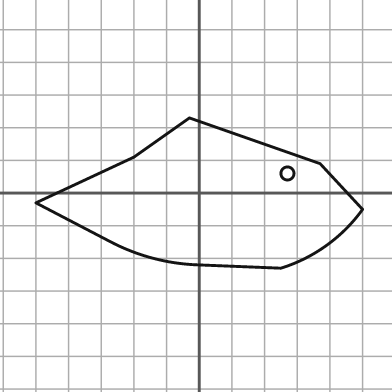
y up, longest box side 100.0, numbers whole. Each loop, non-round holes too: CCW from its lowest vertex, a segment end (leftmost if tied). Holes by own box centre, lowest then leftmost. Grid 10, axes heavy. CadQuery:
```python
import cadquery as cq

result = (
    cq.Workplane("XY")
    .moveTo(25.0, -23.0)
    .threePointArc((39.0, -16.0), (50.0, -5.0))
    .lineTo(37.0, 9.0)
    .lineTo(-3.0, 23.0)
    .lineTo(-20.0, 11.0)
    .lineTo(-50.0, -3.0)
    .lineTo(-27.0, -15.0)
    .threePointArc((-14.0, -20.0), (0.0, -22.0))
    .close()
    .moveTo(27.0, 6.0)
    .circle(2.0)
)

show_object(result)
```